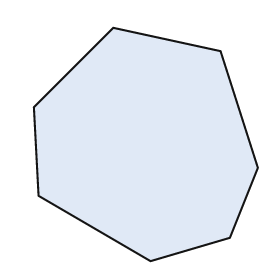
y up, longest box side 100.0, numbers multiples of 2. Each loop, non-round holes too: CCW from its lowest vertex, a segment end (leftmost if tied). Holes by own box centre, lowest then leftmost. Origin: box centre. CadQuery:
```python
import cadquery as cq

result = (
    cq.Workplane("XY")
    .moveTo(2.0, -50.0)
    .lineTo(36.0, -40.0)
    .lineTo(48.0, -10.0)
    .lineTo(32.0, 40.0)
    .lineTo(-14.0, 50.0)
    .lineTo(-48.0, 16.0)
    .lineTo(-46.0, -22.0)
    .close()
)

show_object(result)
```